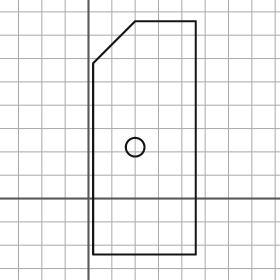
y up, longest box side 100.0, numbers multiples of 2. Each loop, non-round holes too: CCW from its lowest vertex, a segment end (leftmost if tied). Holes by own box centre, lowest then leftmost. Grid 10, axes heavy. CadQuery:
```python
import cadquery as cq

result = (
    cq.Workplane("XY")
    .moveTo(2.0, -24.0)
    .lineTo(46.0, -24.0)
    .lineTo(46.0, 76.0)
    .lineTo(20.0, 76.0)
    .lineTo(2.0, 58.0)
    .close()
    .moveTo(20.0, 22.0)
    .circle(4.0)
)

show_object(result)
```